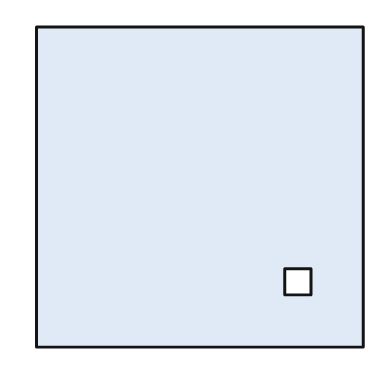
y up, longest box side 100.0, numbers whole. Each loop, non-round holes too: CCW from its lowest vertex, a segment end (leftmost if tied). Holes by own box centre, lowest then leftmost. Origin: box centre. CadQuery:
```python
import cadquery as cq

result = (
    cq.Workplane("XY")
    .moveTo(-50.0, -49.0)
    .lineTo(50.0, -49.0)
    .lineTo(50.0, 49.0)
    .lineTo(-50.0, 49.0)
    .close()
    .moveTo(26.0, -33.0)
    .lineTo(34.0, -33.0)
    .lineTo(34.0, -25.0)
    .lineTo(26.0, -25.0)
    .close()
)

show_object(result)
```